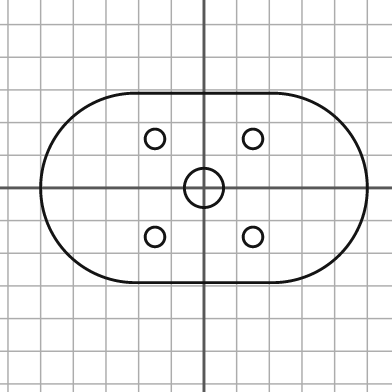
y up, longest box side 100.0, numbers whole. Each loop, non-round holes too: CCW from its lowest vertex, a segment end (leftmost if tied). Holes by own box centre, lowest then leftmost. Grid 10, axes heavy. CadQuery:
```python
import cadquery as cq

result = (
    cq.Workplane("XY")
    .moveTo(-21.0, -29.0)
    .lineTo(21.0, -29.0)
    .threePointArc((50.0, 0.0), (21.0, 29.0))
    .lineTo(-21.0, 29.0)
    .threePointArc((-50.0, 0.0), (-21.0, -29.0))
    .close()
    .moveTo(-15.0, -15.0)
    .circle(3.0)
    .moveTo(15.0, -15.0)
    .circle(3.0)
    .moveTo(0.0, 0.0)
    .circle(6.0)
    .moveTo(-15.0, 15.0)
    .circle(3.0)
    .moveTo(15.0, 15.0)
    .circle(3.0)
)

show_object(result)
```